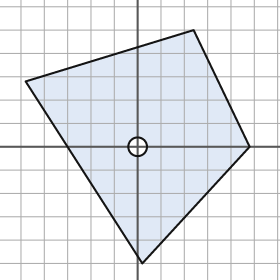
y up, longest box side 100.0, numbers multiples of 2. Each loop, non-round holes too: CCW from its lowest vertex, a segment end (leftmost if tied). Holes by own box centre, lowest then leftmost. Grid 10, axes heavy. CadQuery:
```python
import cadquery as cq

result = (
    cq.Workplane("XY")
    .moveTo(2.0, -50.0)
    .lineTo(48.0, 0.0)
    .lineTo(24.0, 50.0)
    .lineTo(-48.0, 28.0)
    .close()
    .moveTo(0.0, 0.0)
    .circle(4.0)
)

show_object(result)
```